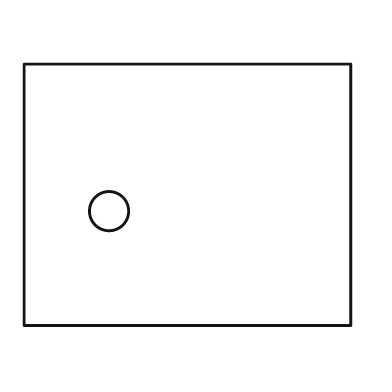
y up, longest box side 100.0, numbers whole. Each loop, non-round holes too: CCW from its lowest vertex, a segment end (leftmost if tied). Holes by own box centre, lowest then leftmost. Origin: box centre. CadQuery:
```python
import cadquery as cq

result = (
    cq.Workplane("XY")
    .moveTo(-50.0, -40.0)
    .lineTo(50.0, -40.0)
    .lineTo(50.0, 40.0)
    .lineTo(-50.0, 40.0)
    .close()
    .moveTo(-24.0, -5.0)
    .circle(6.0)
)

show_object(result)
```